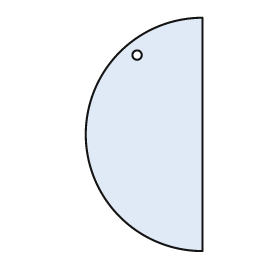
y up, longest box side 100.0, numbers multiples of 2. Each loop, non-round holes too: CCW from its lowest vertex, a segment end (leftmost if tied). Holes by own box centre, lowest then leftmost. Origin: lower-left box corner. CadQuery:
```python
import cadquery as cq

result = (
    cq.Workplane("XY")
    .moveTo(50.0, 0.0)
    .lineTo(50.0, 100.0)
    .threePointArc((0.0, 50.0), (50.0, 0.0))
    .close()
    .moveTo(22.0, 84.0)
    .circle(2.0)
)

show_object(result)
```